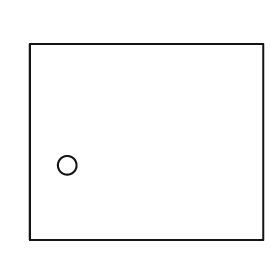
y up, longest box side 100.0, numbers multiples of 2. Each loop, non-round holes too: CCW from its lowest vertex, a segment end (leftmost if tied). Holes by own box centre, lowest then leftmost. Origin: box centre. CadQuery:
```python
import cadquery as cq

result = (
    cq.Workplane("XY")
    .moveTo(-50.0, -42.0)
    .lineTo(50.0, -42.0)
    .lineTo(50.0, 42.0)
    .lineTo(-50.0, 42.0)
    .close()
    .moveTo(-34.0, -10.0)
    .circle(4.0)
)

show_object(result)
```